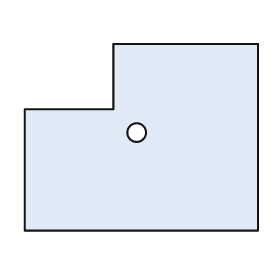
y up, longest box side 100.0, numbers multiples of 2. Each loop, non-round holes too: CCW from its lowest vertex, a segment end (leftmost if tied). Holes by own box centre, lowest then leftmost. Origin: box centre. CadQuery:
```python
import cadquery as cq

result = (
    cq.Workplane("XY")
    .moveTo(-50.0, -40.0)
    .lineTo(50.0, -40.0)
    .lineTo(50.0, 40.0)
    .lineTo(-12.0, 40.0)
    .lineTo(-12.0, 12.0)
    .lineTo(-50.0, 12.0)
    .close()
    .moveTo(-2.0, 2.0)
    .circle(4.0)
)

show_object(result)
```